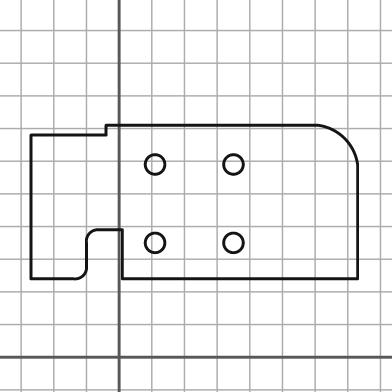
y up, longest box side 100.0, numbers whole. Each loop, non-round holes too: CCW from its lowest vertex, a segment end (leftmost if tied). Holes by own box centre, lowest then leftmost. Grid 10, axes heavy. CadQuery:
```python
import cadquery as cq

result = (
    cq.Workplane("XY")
    .moveTo(-27.0, 24.0)
    .lineTo(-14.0, 24.0)
    .threePointArc((-11.0, 25.0), (-10.0, 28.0))
    .lineTo(-10.0, 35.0)
    .threePointArc((-9.0, 38.0), (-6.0, 39.0))
    .lineTo(1.0, 39.0)
    .lineTo(1.0, 24.0)
    .lineTo(73.0, 24.0)
    .lineTo(73.0, 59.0)
    .threePointArc((69.0, 67.0), (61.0, 71.0))
    .lineTo(-4.0, 71.0)
    .lineTo(-4.0, 68.0)
    .lineTo(-27.0, 68.0)
    .close()
    .moveTo(11.0, 35.0)
    .circle(3.0)
    .moveTo(35.0, 35.0)
    .circle(3.0)
    .moveTo(11.0, 59.0)
    .circle(3.0)
    .moveTo(35.0, 59.0)
    .circle(3.0)
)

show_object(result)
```